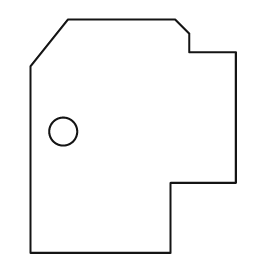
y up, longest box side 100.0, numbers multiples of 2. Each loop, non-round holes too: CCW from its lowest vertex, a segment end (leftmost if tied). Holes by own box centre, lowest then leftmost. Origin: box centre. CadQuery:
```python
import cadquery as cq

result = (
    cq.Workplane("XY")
    .moveTo(-44.0, -50.0)
    .lineTo(16.0, -50.0)
    .lineTo(16.0, -20.0)
    .lineTo(44.0, -20.0)
    .lineTo(44.0, 36.0)
    .lineTo(24.0, 36.0)
    .lineTo(24.0, 44.0)
    .lineTo(18.0, 50.0)
    .lineTo(-28.0, 50.0)
    .lineTo(-44.0, 30.0)
    .close()
    .moveTo(-30.0, 2.0)
    .circle(6.0)
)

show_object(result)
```